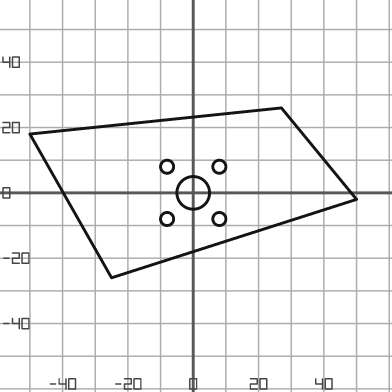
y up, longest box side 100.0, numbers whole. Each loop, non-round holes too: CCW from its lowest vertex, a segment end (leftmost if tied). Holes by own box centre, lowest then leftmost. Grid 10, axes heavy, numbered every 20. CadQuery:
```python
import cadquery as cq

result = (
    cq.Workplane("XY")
    .moveTo(-25.0, -26.0)
    .lineTo(50.0, -2.0)
    .lineTo(27.0, 26.0)
    .lineTo(-50.0, 18.0)
    .close()
    .moveTo(-8.0, -8.0)
    .circle(2.0)
    .moveTo(8.0, -8.0)
    .circle(2.0)
    .moveTo(0.0, 0.0)
    .circle(5.0)
    .moveTo(-8.0, 8.0)
    .circle(2.0)
    .moveTo(8.0, 8.0)
    .circle(2.0)
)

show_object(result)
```